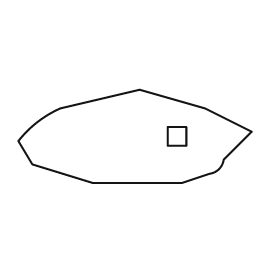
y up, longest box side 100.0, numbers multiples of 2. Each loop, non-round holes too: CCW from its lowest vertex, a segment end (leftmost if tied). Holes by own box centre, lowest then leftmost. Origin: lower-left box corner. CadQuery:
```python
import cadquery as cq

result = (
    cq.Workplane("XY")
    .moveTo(32.0, 0.0)
    .lineTo(70.0, 0.0)
    .lineTo(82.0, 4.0)
    .threePointArc((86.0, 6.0), (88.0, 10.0))
    .lineTo(100.0, 22.0)
    .lineTo(80.0, 32.0)
    .lineTo(52.0, 40.0)
    .lineTo(18.0, 32.0)
    .threePointArc((8.0, 26.0), (0.0, 18.0))
    .lineTo(6.0, 8.0)
    .close()
    .moveTo(64.0, 16.0)
    .lineTo(72.0, 16.0)
    .lineTo(72.0, 24.0)
    .lineTo(64.0, 24.0)
    .close()
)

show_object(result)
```